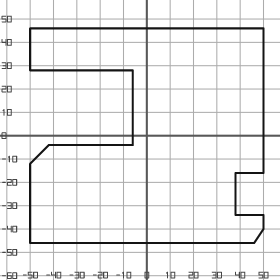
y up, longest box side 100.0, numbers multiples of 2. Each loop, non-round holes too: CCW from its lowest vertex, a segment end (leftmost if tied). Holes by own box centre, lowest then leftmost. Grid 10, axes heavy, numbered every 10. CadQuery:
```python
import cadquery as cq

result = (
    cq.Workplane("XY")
    .moveTo(-50.0, -46.0)
    .lineTo(46.0, -46.0)
    .lineTo(50.0, -40.0)
    .lineTo(50.0, -34.0)
    .lineTo(38.0, -34.0)
    .lineTo(38.0, -16.0)
    .lineTo(50.0, -16.0)
    .lineTo(50.0, 46.0)
    .lineTo(-50.0, 46.0)
    .lineTo(-50.0, 28.0)
    .lineTo(-6.0, 28.0)
    .lineTo(-6.0, -4.0)
    .lineTo(-42.0, -4.0)
    .lineTo(-50.0, -12.0)
    .close()
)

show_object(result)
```